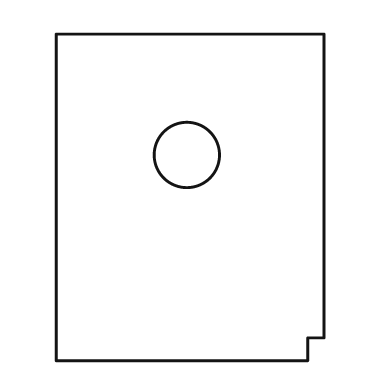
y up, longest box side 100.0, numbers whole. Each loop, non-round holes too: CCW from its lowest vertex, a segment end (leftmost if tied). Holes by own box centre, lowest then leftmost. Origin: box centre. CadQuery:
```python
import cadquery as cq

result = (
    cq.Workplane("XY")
    .moveTo(-41.0, -50.0)
    .lineTo(36.0, -50.0)
    .lineTo(36.0, -43.0)
    .lineTo(41.0, -43.0)
    .lineTo(41.0, 50.0)
    .lineTo(-41.0, 50.0)
    .close()
    .moveTo(-1.0, 13.0)
    .circle(10.0)
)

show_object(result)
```